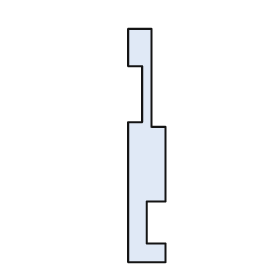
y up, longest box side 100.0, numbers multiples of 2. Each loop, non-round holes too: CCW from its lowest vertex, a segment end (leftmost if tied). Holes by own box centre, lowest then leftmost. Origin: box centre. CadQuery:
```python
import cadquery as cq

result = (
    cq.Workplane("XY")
    .moveTo(-8.0, -50.0)
    .lineTo(8.0, -50.0)
    .lineTo(8.0, -42.0)
    .lineTo(0.0, -42.0)
    .lineTo(0.0, -24.0)
    .lineTo(8.0, -24.0)
    .lineTo(8.0, 8.0)
    .lineTo(2.0, 8.0)
    .lineTo(2.0, 50.0)
    .lineTo(-8.0, 50.0)
    .lineTo(-8.0, 34.0)
    .lineTo(-2.0, 34.0)
    .lineTo(-2.0, 10.0)
    .lineTo(-8.0, 10.0)
    .close()
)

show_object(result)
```